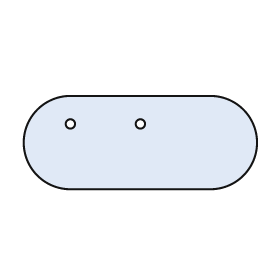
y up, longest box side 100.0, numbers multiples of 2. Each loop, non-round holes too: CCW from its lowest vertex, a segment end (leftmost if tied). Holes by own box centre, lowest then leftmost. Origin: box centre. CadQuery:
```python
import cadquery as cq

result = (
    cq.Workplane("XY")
    .moveTo(-30.0, -20.0)
    .lineTo(30.0, -20.0)
    .threePointArc((50.0, 0.0), (30.0, 20.0))
    .lineTo(-30.0, 20.0)
    .threePointArc((-50.0, 0.0), (-30.0, -20.0))
    .close()
    .moveTo(-30.0, 8.0)
    .circle(2.0)
    .moveTo(0.0, 8.0)
    .circle(2.0)
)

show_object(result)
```